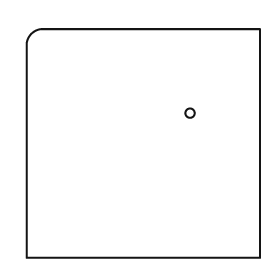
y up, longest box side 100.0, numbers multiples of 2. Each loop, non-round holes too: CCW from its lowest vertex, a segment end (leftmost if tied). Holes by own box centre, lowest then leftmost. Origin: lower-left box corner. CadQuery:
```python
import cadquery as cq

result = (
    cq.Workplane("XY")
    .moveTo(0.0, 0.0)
    .lineTo(100.0, 0.0)
    .lineTo(100.0, 98.0)
    .lineTo(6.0, 98.0)
    .threePointArc((2.0, 96.0), (0.0, 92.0))
    .close()
    .moveTo(70.0, 62.0)
    .circle(2.0)
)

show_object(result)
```